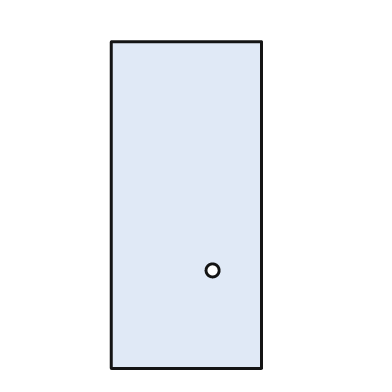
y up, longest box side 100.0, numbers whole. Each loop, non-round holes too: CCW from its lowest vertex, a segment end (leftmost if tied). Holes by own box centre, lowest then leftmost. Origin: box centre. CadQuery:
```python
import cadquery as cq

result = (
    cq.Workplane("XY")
    .moveTo(-23.0, -50.0)
    .lineTo(23.0, -50.0)
    .lineTo(23.0, 50.0)
    .lineTo(-23.0, 50.0)
    .close()
    .moveTo(8.0, -20.0)
    .circle(2.0)
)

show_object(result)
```